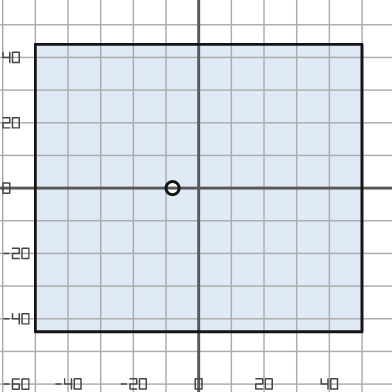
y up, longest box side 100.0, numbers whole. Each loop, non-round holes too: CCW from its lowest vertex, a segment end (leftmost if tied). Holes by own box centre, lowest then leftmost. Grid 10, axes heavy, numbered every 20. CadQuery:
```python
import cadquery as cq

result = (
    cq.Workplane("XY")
    .moveTo(-50.0, -44.0)
    .lineTo(50.0, -44.0)
    .lineTo(50.0, 44.0)
    .lineTo(-50.0, 44.0)
    .close()
    .moveTo(-8.0, 0.0)
    .circle(2.0)
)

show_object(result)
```